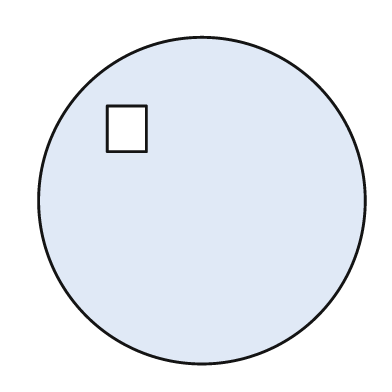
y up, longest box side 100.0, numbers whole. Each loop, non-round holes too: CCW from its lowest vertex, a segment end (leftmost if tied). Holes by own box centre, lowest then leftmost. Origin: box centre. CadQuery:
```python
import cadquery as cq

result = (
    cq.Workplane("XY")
    .moveTo(0.0, 0.0)
    .circle(50.0)
    .moveTo(-29.0, 15.0)
    .lineTo(-17.0, 15.0)
    .lineTo(-17.0, 29.0)
    .lineTo(-29.0, 29.0)
    .close()
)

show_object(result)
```